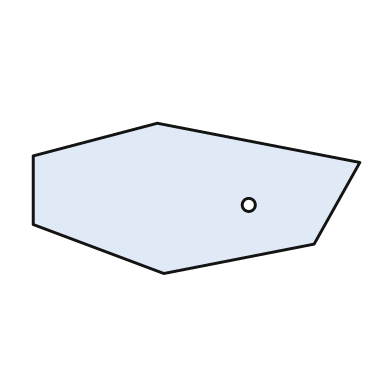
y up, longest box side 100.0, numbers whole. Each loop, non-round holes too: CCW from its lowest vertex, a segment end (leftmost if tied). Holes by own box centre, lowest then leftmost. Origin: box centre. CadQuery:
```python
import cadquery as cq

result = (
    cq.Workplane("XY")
    .moveTo(-10.0, -23.0)
    .lineTo(36.0, -14.0)
    .lineTo(50.0, 11.0)
    .lineTo(-12.0, 23.0)
    .lineTo(-50.0, 13.0)
    .lineTo(-50.0, -8.0)
    .close()
    .moveTo(16.0, -2.0)
    .circle(2.0)
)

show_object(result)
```